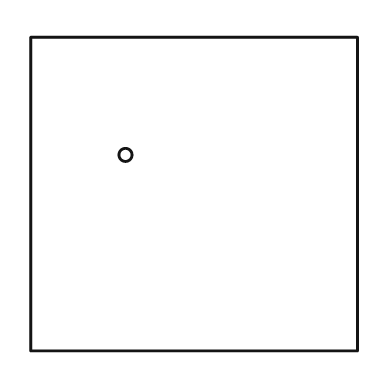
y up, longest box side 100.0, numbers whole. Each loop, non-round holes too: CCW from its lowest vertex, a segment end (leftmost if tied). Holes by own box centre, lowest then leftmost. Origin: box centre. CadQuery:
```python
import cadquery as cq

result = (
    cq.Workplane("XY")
    .moveTo(-50.0, -48.0)
    .lineTo(50.0, -48.0)
    .lineTo(50.0, 48.0)
    .lineTo(-50.0, 48.0)
    .close()
    .moveTo(-21.0, 12.0)
    .circle(2.0)
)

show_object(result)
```